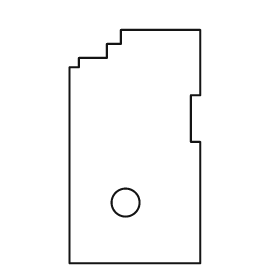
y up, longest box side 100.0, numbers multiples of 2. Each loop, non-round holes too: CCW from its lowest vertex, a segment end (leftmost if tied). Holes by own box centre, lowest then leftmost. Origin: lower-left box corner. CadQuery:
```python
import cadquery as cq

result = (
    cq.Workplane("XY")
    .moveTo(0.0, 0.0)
    .lineTo(56.0, 0.0)
    .lineTo(56.0, 52.0)
    .lineTo(52.0, 52.0)
    .lineTo(52.0, 72.0)
    .lineTo(56.0, 72.0)
    .lineTo(56.0, 100.0)
    .lineTo(22.0, 100.0)
    .lineTo(22.0, 94.0)
    .lineTo(16.0, 94.0)
    .lineTo(16.0, 88.0)
    .lineTo(4.0, 88.0)
    .lineTo(4.0, 84.0)
    .lineTo(0.0, 84.0)
    .close()
    .moveTo(24.0, 26.0)
    .circle(6.0)
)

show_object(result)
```